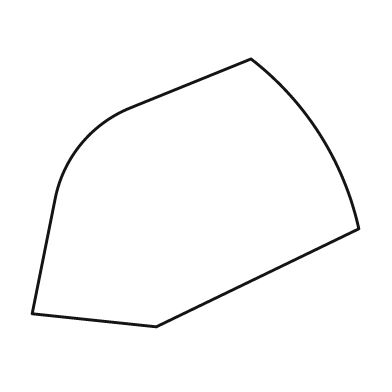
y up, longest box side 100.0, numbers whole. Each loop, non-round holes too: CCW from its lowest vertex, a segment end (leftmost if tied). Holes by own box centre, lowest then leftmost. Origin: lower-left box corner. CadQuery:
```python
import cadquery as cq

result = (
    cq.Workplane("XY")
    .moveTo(38.0, 0.0)
    .lineTo(100.0, 30.0)
    .threePointArc((88.0, 59.0), (67.0, 82.0))
    .lineTo(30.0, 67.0)
    .threePointArc((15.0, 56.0), (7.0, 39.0))
    .lineTo(0.0, 4.0)
    .close()
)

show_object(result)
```